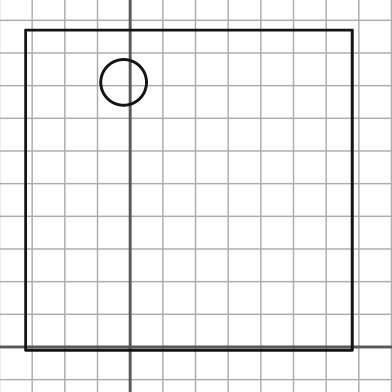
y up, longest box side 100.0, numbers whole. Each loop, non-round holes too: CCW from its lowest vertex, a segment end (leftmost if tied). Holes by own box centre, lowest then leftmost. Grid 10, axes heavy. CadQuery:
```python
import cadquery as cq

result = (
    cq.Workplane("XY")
    .moveTo(-32.0, -1.0)
    .lineTo(68.0, -1.0)
    .lineTo(68.0, 97.0)
    .lineTo(-32.0, 97.0)
    .close()
    .moveTo(-2.0, 81.0)
    .circle(7.0)
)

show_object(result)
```